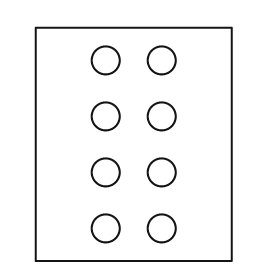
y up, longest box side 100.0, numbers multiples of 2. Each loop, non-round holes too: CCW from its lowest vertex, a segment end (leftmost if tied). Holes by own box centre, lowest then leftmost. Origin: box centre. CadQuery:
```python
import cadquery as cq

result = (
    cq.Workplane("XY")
    .moveTo(-42.0, -50.0)
    .lineTo(42.0, -50.0)
    .lineTo(42.0, 50.0)
    .lineTo(-42.0, 50.0)
    .close()
    .moveTo(-12.0, -36.0)
    .circle(6.0)
    .moveTo(12.0, -36.0)
    .circle(6.0)
    .moveTo(-12.0, -12.0)
    .circle(6.0)
    .moveTo(12.0, -12.0)
    .circle(6.0)
    .moveTo(-12.0, 12.0)
    .circle(6.0)
    .moveTo(12.0, 12.0)
    .circle(6.0)
    .moveTo(-12.0, 36.0)
    .circle(6.0)
    .moveTo(12.0, 36.0)
    .circle(6.0)
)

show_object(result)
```